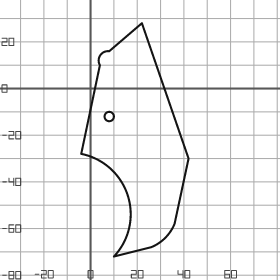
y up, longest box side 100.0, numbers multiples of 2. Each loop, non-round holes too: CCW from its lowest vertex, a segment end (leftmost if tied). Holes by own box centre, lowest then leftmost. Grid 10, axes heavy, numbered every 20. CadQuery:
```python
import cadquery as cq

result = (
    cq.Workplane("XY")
    .moveTo(10.0, -72.0)
    .lineTo(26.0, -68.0)
    .threePointArc((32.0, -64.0), (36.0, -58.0))
    .lineTo(42.0, -30.0)
    .lineTo(22.0, 28.0)
    .lineTo(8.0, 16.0)
    .threePointArc((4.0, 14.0), (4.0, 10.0))
    .lineTo(-4.0, -28.0)
    .threePointArc((16.0, -46.0), (10.0, -72.0))
    .close()
    .moveTo(8.0, -12.0)
    .circle(2.0)
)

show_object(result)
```